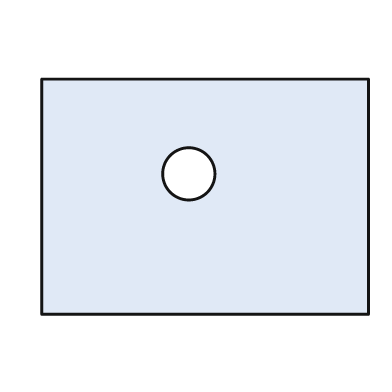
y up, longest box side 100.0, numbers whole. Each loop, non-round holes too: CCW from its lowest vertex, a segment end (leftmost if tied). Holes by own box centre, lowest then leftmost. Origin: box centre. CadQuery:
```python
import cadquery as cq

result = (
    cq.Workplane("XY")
    .moveTo(-50.0, -36.0)
    .lineTo(50.0, -36.0)
    .lineTo(50.0, 36.0)
    .lineTo(-50.0, 36.0)
    .close()
    .moveTo(-5.0, 7.0)
    .circle(8.0)
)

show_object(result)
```